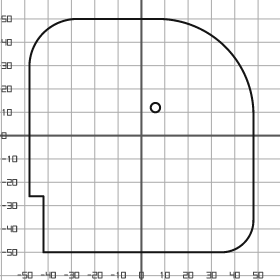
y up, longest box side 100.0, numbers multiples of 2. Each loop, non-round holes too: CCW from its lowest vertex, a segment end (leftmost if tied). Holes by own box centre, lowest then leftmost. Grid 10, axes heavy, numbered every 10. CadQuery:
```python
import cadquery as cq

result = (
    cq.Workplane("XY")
    .moveTo(-42.0, -50.0)
    .lineTo(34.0, -50.0)
    .threePointArc((44.0, -46.0), (48.0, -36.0))
    .lineTo(48.0, 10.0)
    .threePointArc((36.0, 38.0), (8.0, 50.0))
    .lineTo(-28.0, 50.0)
    .threePointArc((-42.0, 44.0), (-48.0, 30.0))
    .lineTo(-48.0, -26.0)
    .lineTo(-42.0, -26.0)
    .close()
    .moveTo(6.0, 12.0)
    .circle(2.0)
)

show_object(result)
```